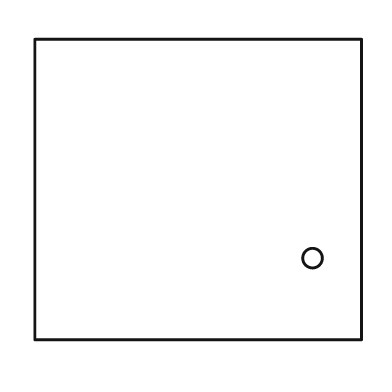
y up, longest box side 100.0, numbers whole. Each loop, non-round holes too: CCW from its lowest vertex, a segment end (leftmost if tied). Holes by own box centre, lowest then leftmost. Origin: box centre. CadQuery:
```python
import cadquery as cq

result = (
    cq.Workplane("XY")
    .moveTo(-50.0, -46.0)
    .lineTo(50.0, -46.0)
    .lineTo(50.0, 46.0)
    .lineTo(-50.0, 46.0)
    .close()
    .moveTo(35.0, -21.0)
    .circle(3.0)
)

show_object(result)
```